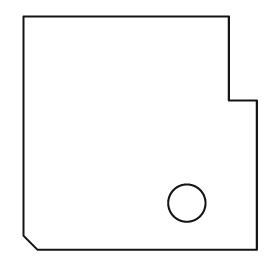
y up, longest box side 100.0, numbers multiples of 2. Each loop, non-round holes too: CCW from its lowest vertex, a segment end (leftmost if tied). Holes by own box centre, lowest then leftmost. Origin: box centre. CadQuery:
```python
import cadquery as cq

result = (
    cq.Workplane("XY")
    .moveTo(-44.0, -50.0)
    .lineTo(50.0, -50.0)
    .lineTo(50.0, 14.0)
    .lineTo(38.0, 14.0)
    .lineTo(38.0, 50.0)
    .lineTo(-50.0, 50.0)
    .lineTo(-50.0, -44.0)
    .close()
    .moveTo(20.0, -30.0)
    .circle(8.0)
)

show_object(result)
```